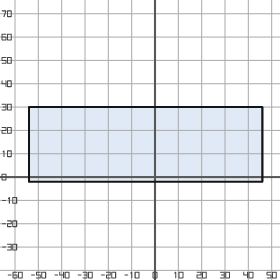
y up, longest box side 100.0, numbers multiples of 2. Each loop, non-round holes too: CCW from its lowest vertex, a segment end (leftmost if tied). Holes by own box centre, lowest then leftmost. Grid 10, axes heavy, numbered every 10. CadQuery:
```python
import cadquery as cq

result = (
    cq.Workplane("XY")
    .moveTo(-54.0, -2.0)
    .lineTo(46.0, -2.0)
    .lineTo(46.0, 30.0)
    .lineTo(-54.0, 30.0)
    .close()
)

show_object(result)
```